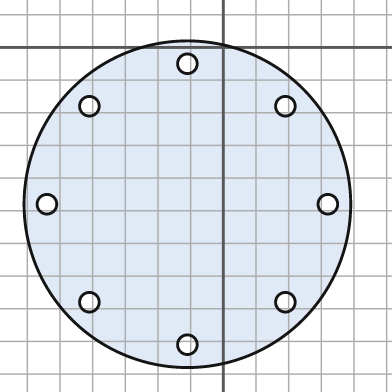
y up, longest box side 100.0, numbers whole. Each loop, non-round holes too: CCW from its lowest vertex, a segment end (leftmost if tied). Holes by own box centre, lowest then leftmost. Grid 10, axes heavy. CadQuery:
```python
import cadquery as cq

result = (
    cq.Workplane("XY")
    .moveTo(-11.0, -48.0)
    .circle(50.0)
    .moveTo(-11.0, -91.0)
    .circle(3.0)
    .moveTo(-41.0, -78.0)
    .circle(3.0)
    .moveTo(19.0, -78.0)
    .circle(3.0)
    .moveTo(-54.0, -48.0)
    .circle(3.0)
    .moveTo(32.0, -48.0)
    .circle(3.0)
    .moveTo(-41.0, -18.0)
    .circle(3.0)
    .moveTo(19.0, -18.0)
    .circle(3.0)
    .moveTo(-11.0, -5.0)
    .circle(3.0)
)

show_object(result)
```